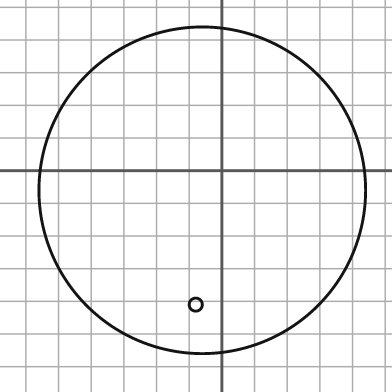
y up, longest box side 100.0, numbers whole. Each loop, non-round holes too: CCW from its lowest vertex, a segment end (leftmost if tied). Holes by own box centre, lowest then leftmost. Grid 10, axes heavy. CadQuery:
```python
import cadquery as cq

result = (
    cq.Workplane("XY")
    .moveTo(-6.0, -6.0)
    .circle(50.0)
    .moveTo(-8.0, -41.0)
    .circle(2.0)
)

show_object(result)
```